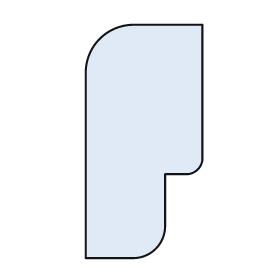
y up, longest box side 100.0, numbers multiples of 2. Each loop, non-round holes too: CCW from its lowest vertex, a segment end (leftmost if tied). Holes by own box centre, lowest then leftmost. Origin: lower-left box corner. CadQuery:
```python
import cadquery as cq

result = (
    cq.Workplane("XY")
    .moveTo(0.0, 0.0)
    .lineTo(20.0, 0.0)
    .threePointArc((30.0, 4.0), (34.0, 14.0))
    .lineTo(34.0, 36.0)
    .lineTo(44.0, 36.0)
    .threePointArc((48.0, 38.0), (50.0, 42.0))
    .lineTo(50.0, 100.0)
    .lineTo(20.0, 100.0)
    .threePointArc((6.0, 94.0), (0.0, 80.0))
    .close()
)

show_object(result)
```